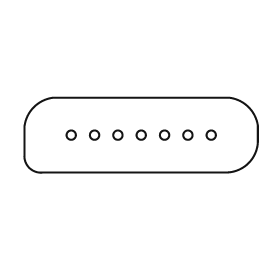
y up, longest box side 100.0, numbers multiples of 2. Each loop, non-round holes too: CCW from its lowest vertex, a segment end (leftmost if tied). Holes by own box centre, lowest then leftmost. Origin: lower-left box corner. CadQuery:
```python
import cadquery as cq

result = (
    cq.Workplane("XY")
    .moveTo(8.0, 0.0)
    .lineTo(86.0, 0.0)
    .threePointArc((96.0, 4.0), (100.0, 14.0))
    .lineTo(100.0, 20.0)
    .threePointArc((96.0, 28.0), (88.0, 32.0))
    .lineTo(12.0, 32.0)
    .threePointArc((4.0, 28.0), (0.0, 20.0))
    .lineTo(0.0, 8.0)
    .threePointArc((2.0, 2.0), (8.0, 0.0))
    .close()
    .moveTo(20.0, 16.0)
    .circle(2.0)
    .moveTo(30.0, 16.0)
    .circle(2.0)
    .moveTo(40.0, 16.0)
    .circle(2.0)
    .moveTo(50.0, 16.0)
    .circle(2.0)
    .moveTo(60.0, 16.0)
    .circle(2.0)
    .moveTo(70.0, 16.0)
    .circle(2.0)
    .moveTo(80.0, 16.0)
    .circle(2.0)
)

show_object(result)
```